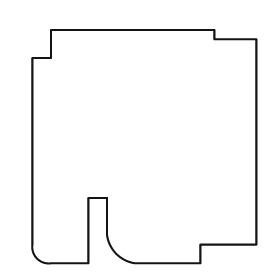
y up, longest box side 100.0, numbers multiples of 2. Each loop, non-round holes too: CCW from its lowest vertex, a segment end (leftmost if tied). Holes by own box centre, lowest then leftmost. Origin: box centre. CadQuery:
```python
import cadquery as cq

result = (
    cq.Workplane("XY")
    .moveTo(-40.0, -50.0)
    .lineTo(-24.0, -50.0)
    .lineTo(-24.0, -22.0)
    .lineTo(-16.0, -22.0)
    .lineTo(-16.0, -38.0)
    .threePointArc((-12.0, -46.0), (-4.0, -50.0))
    .lineTo(24.0, -50.0)
    .lineTo(24.0, -42.0)
    .lineTo(48.0, -42.0)
    .lineTo(48.0, 46.0)
    .lineTo(30.0, 46.0)
    .lineTo(30.0, 50.0)
    .lineTo(-40.0, 50.0)
    .lineTo(-40.0, 38.0)
    .lineTo(-48.0, 38.0)
    .lineTo(-48.0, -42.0)
    .threePointArc((-46.0, -48.0), (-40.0, -50.0))
    .close()
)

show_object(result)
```